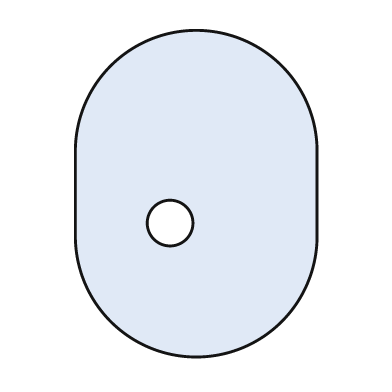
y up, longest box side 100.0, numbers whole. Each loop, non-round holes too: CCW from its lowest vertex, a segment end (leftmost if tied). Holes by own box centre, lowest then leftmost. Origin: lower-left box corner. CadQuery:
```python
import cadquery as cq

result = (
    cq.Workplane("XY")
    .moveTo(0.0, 37.0)
    .threePointArc((37.0, 0.0), (74.0, 37.0))
    .lineTo(74.0, 63.0)
    .threePointArc((37.0, 100.0), (0.0, 63.0))
    .close()
    .moveTo(29.0, 41.0)
    .circle(7.0)
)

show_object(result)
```